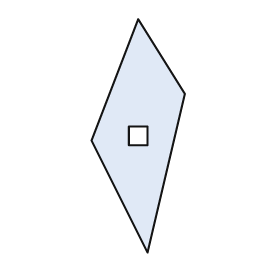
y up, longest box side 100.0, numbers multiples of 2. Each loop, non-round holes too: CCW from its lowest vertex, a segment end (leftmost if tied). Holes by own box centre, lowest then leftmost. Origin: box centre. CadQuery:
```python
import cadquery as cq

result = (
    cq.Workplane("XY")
    .moveTo(4.0, -50.0)
    .lineTo(20.0, 18.0)
    .lineTo(0.0, 50.0)
    .lineTo(-20.0, -2.0)
    .close()
    .moveTo(-4.0, -4.0)
    .lineTo(4.0, -4.0)
    .lineTo(4.0, 4.0)
    .lineTo(-4.0, 4.0)
    .close()
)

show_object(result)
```